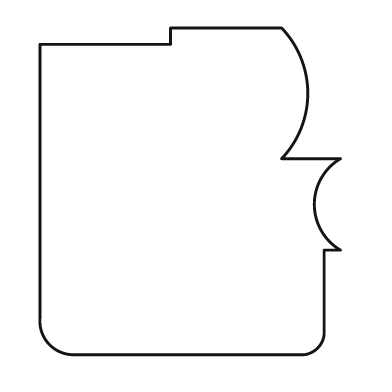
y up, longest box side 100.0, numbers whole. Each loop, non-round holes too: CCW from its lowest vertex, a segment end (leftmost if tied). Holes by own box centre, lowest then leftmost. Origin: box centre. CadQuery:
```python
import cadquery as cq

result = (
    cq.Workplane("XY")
    .moveTo(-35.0, -50.0)
    .lineTo(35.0, -50.0)
    .threePointArc((39.0, -48.0), (41.0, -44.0))
    .lineTo(41.0, -18.0)
    .lineTo(46.0, -18.0)
    .threePointArc((38.0, -4.0), (46.0, 10.0))
    .lineTo(28.0, 10.0)
    .threePointArc((36.0, 30.0), (28.0, 50.0))
    .lineTo(-6.0, 50.0)
    .lineTo(-6.0, 45.0)
    .lineTo(-46.0, 45.0)
    .lineTo(-46.0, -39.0)
    .threePointArc((-43.0, -47.0), (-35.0, -50.0))
    .close()
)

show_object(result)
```